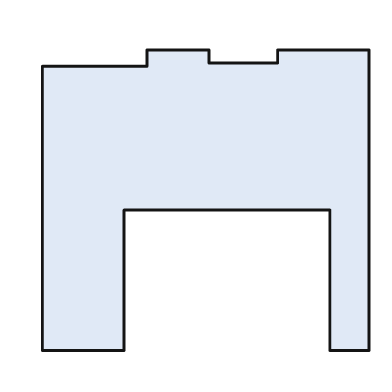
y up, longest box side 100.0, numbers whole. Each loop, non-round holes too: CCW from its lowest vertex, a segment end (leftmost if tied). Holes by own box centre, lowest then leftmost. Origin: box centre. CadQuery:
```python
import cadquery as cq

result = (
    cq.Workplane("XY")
    .moveTo(-50.0, -46.0)
    .lineTo(-25.0, -46.0)
    .lineTo(-25.0, -3.0)
    .lineTo(38.0, -3.0)
    .lineTo(38.0, -46.0)
    .lineTo(50.0, -46.0)
    .lineTo(50.0, 46.0)
    .lineTo(22.0, 46.0)
    .lineTo(22.0, 42.0)
    .lineTo(1.0, 42.0)
    .lineTo(1.0, 46.0)
    .lineTo(-18.0, 46.0)
    .lineTo(-18.0, 41.0)
    .lineTo(-50.0, 41.0)
    .close()
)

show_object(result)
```